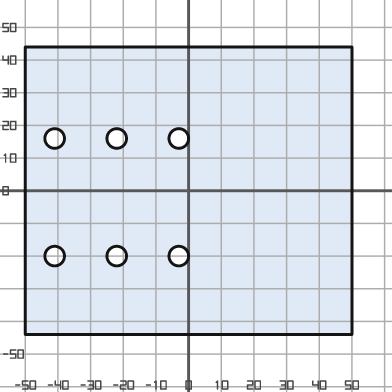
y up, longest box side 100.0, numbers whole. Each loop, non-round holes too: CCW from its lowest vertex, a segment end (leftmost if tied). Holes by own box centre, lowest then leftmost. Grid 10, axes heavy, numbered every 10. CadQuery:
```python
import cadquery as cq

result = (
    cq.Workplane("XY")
    .moveTo(-50.0, -44.0)
    .lineTo(50.0, -44.0)
    .lineTo(50.0, 44.0)
    .lineTo(-50.0, 44.0)
    .close()
    .moveTo(-41.0, -20.0)
    .circle(3.0)
    .moveTo(-22.0, -20.0)
    .circle(3.0)
    .moveTo(-3.0, -20.0)
    .circle(3.0)
    .moveTo(-41.0, 16.0)
    .circle(3.0)
    .moveTo(-22.0, 16.0)
    .circle(3.0)
    .moveTo(-3.0, 16.0)
    .circle(3.0)
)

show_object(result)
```